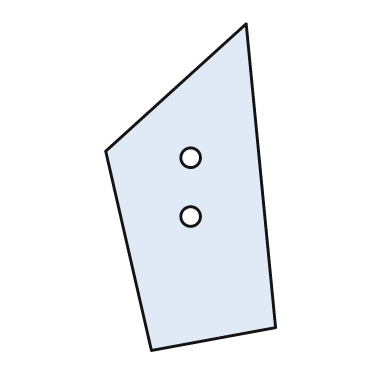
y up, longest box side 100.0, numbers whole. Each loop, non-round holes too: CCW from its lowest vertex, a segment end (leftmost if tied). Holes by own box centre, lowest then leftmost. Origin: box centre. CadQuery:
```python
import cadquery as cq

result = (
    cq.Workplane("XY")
    .moveTo(-12.0, -50.0)
    .lineTo(26.0, -43.0)
    .lineTo(17.0, 50.0)
    .lineTo(-26.0, 11.0)
    .close()
    .moveTo(0.0, -9.0)
    .circle(3.0)
    .moveTo(0.0, 9.0)
    .circle(3.0)
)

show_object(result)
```